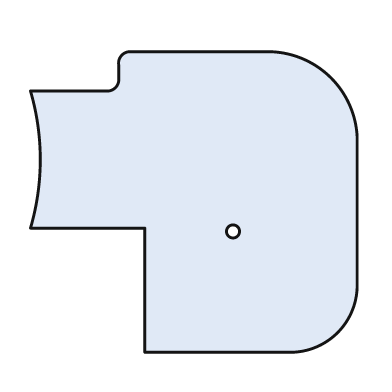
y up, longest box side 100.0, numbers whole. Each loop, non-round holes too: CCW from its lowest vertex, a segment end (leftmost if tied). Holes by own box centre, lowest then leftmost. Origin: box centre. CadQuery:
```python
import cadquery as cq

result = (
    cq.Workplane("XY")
    .moveTo(-15.0, -46.0)
    .lineTo(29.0, -46.0)
    .threePointArc((44.0, -40.0), (50.0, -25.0))
    .lineTo(50.0, 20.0)
    .threePointArc((42.0, 38.0), (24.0, 46.0))
    .lineTo(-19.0, 46.0)
    .threePointArc((-22.0, 45.0), (-23.0, 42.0))
    .lineTo(-23.0, 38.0)
    .threePointArc((-24.0, 35.0), (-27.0, 34.0))
    .lineTo(-50.0, 34.0)
    .threePointArc((-47.0, 13.0), (-50.0, -8.0))
    .lineTo(-15.0, -8.0)
    .close()
    .moveTo(12.0, -9.0)
    .circle(2.0)
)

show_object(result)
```